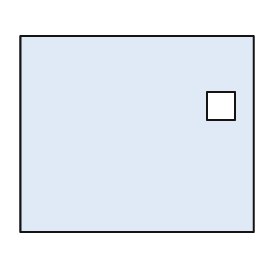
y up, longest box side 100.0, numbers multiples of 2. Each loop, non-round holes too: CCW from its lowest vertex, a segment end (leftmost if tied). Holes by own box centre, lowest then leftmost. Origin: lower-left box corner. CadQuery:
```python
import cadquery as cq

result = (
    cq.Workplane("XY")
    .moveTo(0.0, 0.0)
    .lineTo(100.0, 0.0)
    .lineTo(100.0, 84.0)
    .lineTo(0.0, 84.0)
    .close()
    .moveTo(80.0, 48.0)
    .lineTo(92.0, 48.0)
    .lineTo(92.0, 60.0)
    .lineTo(80.0, 60.0)
    .close()
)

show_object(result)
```